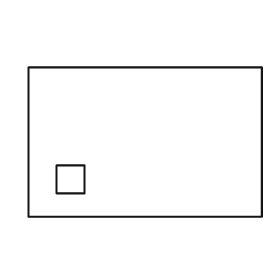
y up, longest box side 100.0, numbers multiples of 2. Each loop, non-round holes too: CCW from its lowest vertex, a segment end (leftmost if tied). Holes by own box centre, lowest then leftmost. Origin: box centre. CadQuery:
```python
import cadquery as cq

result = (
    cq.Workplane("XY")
    .moveTo(-50.0, -32.0)
    .lineTo(50.0, -32.0)
    .lineTo(50.0, 32.0)
    .lineTo(-50.0, 32.0)
    .close()
    .moveTo(-38.0, -22.0)
    .lineTo(-26.0, -22.0)
    .lineTo(-26.0, -10.0)
    .lineTo(-38.0, -10.0)
    .close()
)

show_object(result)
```